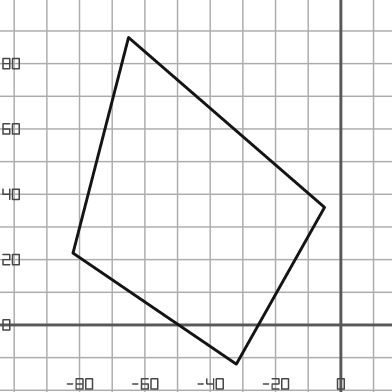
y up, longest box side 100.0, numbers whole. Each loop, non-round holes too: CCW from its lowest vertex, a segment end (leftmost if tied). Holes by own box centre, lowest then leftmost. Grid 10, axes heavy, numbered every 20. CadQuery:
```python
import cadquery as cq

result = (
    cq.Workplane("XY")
    .moveTo(-32.0, -12.0)
    .lineTo(-5.0, 36.0)
    .lineTo(-65.0, 88.0)
    .lineTo(-82.0, 22.0)
    .close()
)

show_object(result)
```